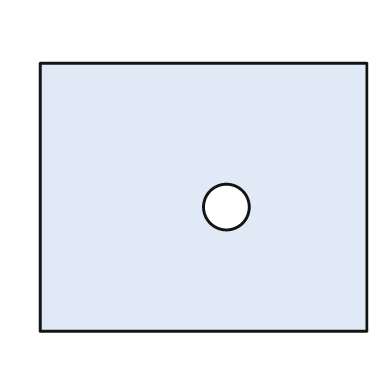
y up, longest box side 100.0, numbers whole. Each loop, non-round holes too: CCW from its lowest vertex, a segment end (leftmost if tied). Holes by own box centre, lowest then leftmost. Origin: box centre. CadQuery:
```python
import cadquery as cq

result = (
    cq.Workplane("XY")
    .moveTo(-50.0, -41.0)
    .lineTo(50.0, -41.0)
    .lineTo(50.0, 41.0)
    .lineTo(-50.0, 41.0)
    .close()
    .moveTo(7.0, -3.0)
    .circle(7.0)
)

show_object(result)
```